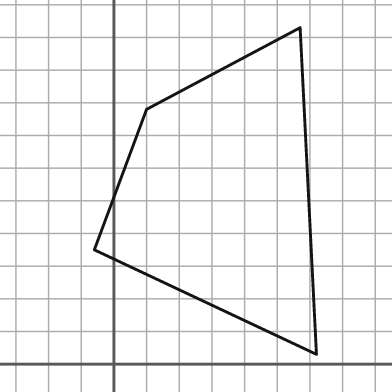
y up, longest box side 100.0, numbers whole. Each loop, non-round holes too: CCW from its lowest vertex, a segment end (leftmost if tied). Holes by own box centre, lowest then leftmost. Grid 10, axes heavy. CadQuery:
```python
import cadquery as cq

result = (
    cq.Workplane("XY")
    .moveTo(62.0, 3.0)
    .lineTo(57.0, 103.0)
    .lineTo(10.0, 78.0)
    .lineTo(-6.0, 35.0)
    .close()
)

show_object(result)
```